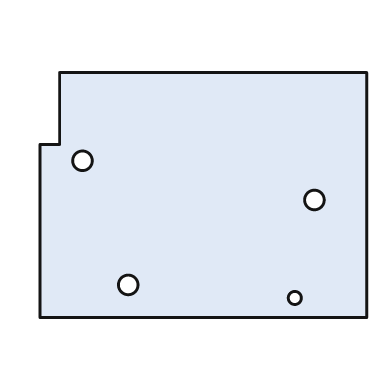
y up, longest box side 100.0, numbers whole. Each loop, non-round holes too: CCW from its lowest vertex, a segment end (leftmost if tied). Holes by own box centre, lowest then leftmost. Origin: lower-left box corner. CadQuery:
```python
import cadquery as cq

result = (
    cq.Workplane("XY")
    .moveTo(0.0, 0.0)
    .lineTo(100.0, 0.0)
    .lineTo(100.0, 75.0)
    .lineTo(6.0, 75.0)
    .lineTo(6.0, 53.0)
    .lineTo(0.0, 53.0)
    .close()
    .moveTo(78.0, 6.0)
    .circle(2.0)
    .moveTo(27.0, 10.0)
    .circle(3.0)
    .moveTo(84.0, 36.0)
    .circle(3.0)
    .moveTo(13.0, 48.0)
    .circle(3.0)
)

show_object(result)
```